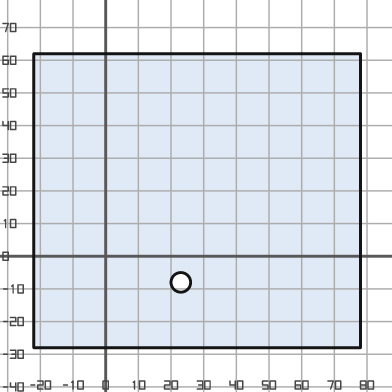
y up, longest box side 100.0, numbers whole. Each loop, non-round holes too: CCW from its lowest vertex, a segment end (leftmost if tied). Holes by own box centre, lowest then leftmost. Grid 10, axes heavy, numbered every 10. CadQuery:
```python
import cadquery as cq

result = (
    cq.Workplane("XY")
    .moveTo(-22.0, -28.0)
    .lineTo(78.0, -28.0)
    .lineTo(78.0, 62.0)
    .lineTo(-22.0, 62.0)
    .close()
    .moveTo(23.0, -8.0)
    .circle(3.0)
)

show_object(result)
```